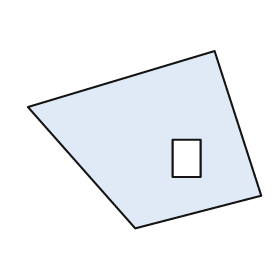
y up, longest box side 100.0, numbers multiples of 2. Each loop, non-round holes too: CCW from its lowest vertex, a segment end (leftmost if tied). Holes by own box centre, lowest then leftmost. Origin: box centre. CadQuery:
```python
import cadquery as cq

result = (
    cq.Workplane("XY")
    .moveTo(-4.0, -38.0)
    .lineTo(50.0, -24.0)
    .lineTo(30.0, 38.0)
    .lineTo(-50.0, 14.0)
    .close()
    .moveTo(12.0, -16.0)
    .lineTo(24.0, -16.0)
    .lineTo(24.0, 0.0)
    .lineTo(12.0, 0.0)
    .close()
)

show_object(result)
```